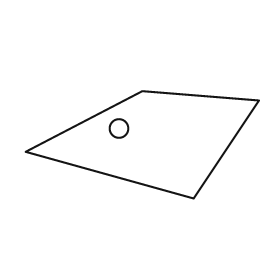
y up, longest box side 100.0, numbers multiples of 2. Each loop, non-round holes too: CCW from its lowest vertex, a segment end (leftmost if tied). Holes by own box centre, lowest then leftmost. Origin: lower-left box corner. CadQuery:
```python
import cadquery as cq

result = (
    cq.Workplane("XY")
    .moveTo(72.0, 0.0)
    .lineTo(100.0, 42.0)
    .lineTo(50.0, 46.0)
    .lineTo(0.0, 20.0)
    .close()
    .moveTo(40.0, 30.0)
    .circle(4.0)
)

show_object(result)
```